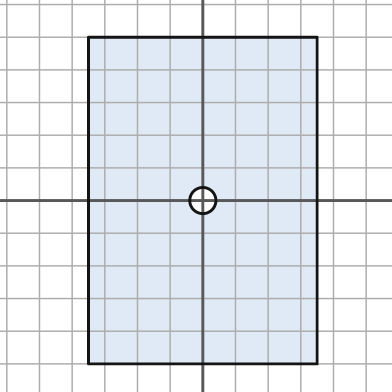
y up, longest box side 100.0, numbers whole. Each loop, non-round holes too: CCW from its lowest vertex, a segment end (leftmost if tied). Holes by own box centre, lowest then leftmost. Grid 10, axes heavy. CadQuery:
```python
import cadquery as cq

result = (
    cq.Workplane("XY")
    .moveTo(-35.0, -50.0)
    .lineTo(35.0, -50.0)
    .lineTo(35.0, 50.0)
    .lineTo(-35.0, 50.0)
    .close()
    .moveTo(0.0, 0.0)
    .circle(4.0)
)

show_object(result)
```